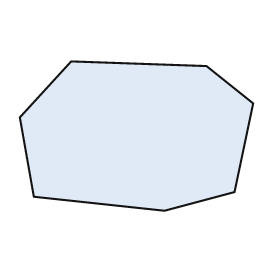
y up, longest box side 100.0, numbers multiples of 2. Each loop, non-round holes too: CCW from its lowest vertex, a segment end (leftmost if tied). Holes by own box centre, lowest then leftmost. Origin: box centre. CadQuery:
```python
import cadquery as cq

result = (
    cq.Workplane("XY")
    .moveTo(12.0, -32.0)
    .lineTo(42.0, -24.0)
    .lineTo(50.0, 14.0)
    .lineTo(30.0, 30.0)
    .lineTo(-28.0, 32.0)
    .lineTo(-50.0, 8.0)
    .lineTo(-44.0, -26.0)
    .close()
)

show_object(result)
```